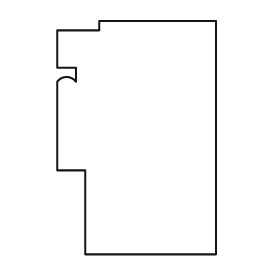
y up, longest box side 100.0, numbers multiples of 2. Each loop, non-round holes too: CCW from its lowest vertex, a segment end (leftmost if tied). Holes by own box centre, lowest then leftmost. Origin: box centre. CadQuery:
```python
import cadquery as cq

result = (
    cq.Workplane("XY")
    .moveTo(-22.0, -50.0)
    .lineTo(34.0, -50.0)
    .lineTo(34.0, 50.0)
    .lineTo(-16.0, 50.0)
    .lineTo(-16.0, 46.0)
    .lineTo(-34.0, 46.0)
    .lineTo(-34.0, 30.0)
    .lineTo(-26.0, 30.0)
    .lineTo(-26.0, 24.0)
    .threePointArc((-30.0, 26.0), (-34.0, 24.0))
    .lineTo(-34.0, -14.0)
    .lineTo(-22.0, -14.0)
    .close()
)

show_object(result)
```